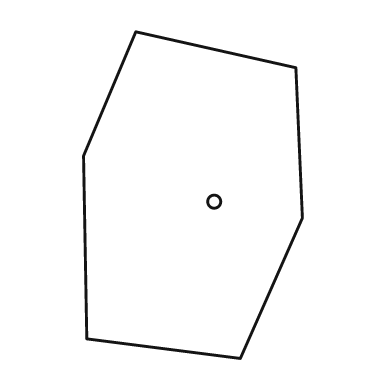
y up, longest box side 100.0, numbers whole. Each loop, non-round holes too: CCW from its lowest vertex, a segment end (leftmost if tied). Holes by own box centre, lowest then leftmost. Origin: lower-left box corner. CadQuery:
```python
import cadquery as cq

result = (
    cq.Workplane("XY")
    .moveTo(48.0, 0.0)
    .lineTo(67.0, 43.0)
    .lineTo(65.0, 89.0)
    .lineTo(16.0, 100.0)
    .lineTo(0.0, 62.0)
    .lineTo(1.0, 6.0)
    .close()
    .moveTo(40.0, 48.0)
    .circle(2.0)
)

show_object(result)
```